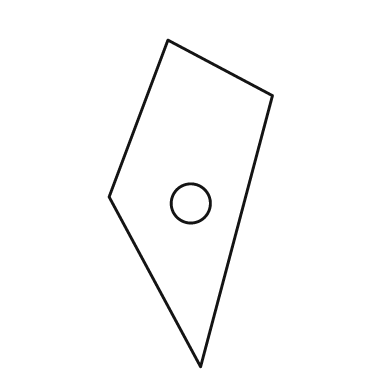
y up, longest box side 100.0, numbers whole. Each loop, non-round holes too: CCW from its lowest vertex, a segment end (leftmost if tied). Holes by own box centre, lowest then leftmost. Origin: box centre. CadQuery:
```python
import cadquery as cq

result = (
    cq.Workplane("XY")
    .moveTo(3.0, -50.0)
    .lineTo(25.0, 33.0)
    .lineTo(-7.0, 50.0)
    .lineTo(-25.0, 2.0)
    .close()
    .moveTo(0.0, 0.0)
    .circle(6.0)
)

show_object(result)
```